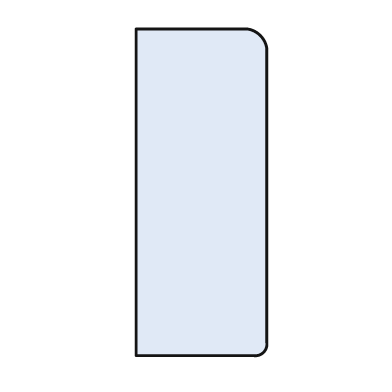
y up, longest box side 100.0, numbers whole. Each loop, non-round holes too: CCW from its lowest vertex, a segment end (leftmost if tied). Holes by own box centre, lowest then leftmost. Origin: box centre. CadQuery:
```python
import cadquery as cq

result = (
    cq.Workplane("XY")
    .moveTo(-20.0, -50.0)
    .lineTo(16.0, -50.0)
    .threePointArc((19.0, -49.0), (20.0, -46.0))
    .lineTo(20.0, 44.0)
    .threePointArc((18.0, 48.0), (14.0, 50.0))
    .lineTo(-20.0, 50.0)
    .close()
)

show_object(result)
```